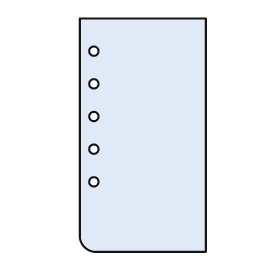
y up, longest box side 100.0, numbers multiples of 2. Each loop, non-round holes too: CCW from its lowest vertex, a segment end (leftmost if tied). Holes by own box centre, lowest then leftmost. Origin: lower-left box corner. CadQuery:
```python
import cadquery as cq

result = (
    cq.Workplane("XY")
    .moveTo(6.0, 0.0)
    .lineTo(54.0, 0.0)
    .lineTo(54.0, 100.0)
    .lineTo(0.0, 100.0)
    .lineTo(0.0, 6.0)
    .threePointArc((2.0, 2.0), (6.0, 0.0))
    .close()
    .moveTo(6.0, 30.0)
    .circle(2.0)
    .moveTo(6.0, 44.0)
    .circle(2.0)
    .moveTo(6.0, 58.0)
    .circle(2.0)
    .moveTo(6.0, 72.0)
    .circle(2.0)
    .moveTo(6.0, 86.0)
    .circle(2.0)
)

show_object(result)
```